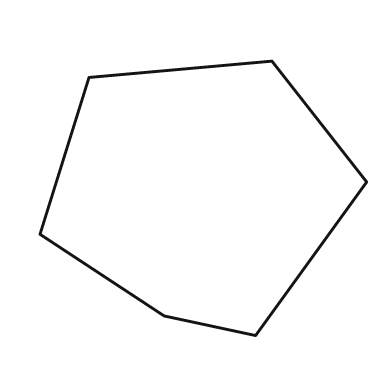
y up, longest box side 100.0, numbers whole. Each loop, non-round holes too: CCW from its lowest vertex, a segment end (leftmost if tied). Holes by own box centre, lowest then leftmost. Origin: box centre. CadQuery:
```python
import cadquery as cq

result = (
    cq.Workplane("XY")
    .moveTo(16.0, -42.0)
    .lineTo(50.0, 5.0)
    .lineTo(21.0, 42.0)
    .lineTo(-35.0, 37.0)
    .lineTo(-50.0, -11.0)
    .lineTo(-12.0, -36.0)
    .close()
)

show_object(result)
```